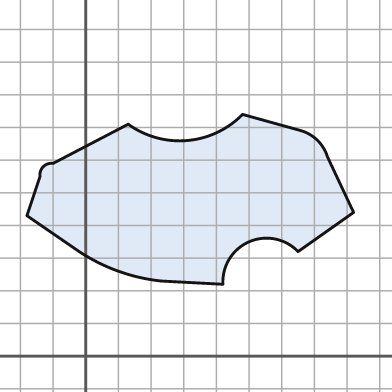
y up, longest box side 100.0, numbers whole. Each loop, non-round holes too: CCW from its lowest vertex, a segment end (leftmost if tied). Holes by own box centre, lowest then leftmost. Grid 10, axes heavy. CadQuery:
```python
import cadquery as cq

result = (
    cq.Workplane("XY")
    .moveTo(42.0, 22.0)
    .threePointArc((50.0, 35.0), (65.0, 32.0))
    .lineTo(82.0, 44.0)
    .lineTo(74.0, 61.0)
    .threePointArc((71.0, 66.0), (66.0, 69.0))
    .lineTo(48.0, 74.0)
    .threePointArc((31.0, 66.0), (13.0, 71.0))
    .lineTo(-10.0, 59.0)
    .threePointArc((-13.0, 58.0), (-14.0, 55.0))
    .lineTo(-18.0, 43.0)
    .lineTo(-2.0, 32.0)
    .threePointArc((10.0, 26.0), (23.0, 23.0))
    .close()
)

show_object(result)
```